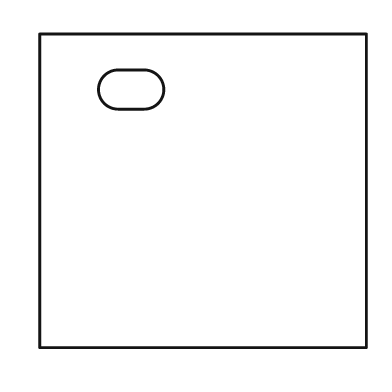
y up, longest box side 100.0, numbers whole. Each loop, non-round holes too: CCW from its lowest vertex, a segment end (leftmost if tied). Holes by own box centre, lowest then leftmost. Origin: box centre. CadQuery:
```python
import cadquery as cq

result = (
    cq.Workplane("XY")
    .moveTo(-50.0, -48.0)
    .lineTo(50.0, -48.0)
    .lineTo(50.0, 48.0)
    .lineTo(-50.0, 48.0)
    .close()
    .moveTo(-26.0, 25.0)
    .lineTo(-18.0, 25.0)
    .threePointArc((-12.0, 31.0), (-18.0, 37.0))
    .lineTo(-26.0, 37.0)
    .threePointArc((-32.0, 31.0), (-26.0, 25.0))
    .close()
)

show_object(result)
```